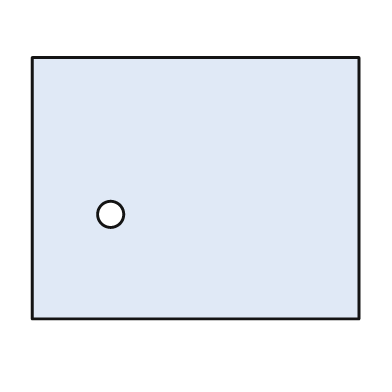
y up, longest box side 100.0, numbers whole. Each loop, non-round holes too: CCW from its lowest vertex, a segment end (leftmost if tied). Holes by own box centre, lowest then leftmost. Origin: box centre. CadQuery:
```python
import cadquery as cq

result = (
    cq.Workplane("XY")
    .moveTo(-50.0, -40.0)
    .lineTo(50.0, -40.0)
    .lineTo(50.0, 40.0)
    .lineTo(-50.0, 40.0)
    .close()
    .moveTo(-26.0, -8.0)
    .circle(4.0)
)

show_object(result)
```